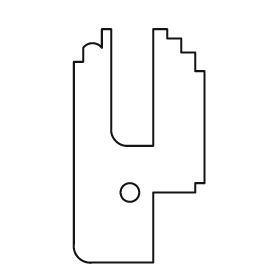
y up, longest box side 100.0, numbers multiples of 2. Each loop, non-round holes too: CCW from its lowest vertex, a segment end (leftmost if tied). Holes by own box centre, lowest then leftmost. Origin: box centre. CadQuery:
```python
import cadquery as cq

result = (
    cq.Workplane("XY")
    .moveTo(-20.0, -50.0)
    .lineTo(6.0, -50.0)
    .lineTo(6.0, -20.0)
    .lineTo(24.0, -20.0)
    .lineTo(24.0, -16.0)
    .lineTo(28.0, -16.0)
    .lineTo(28.0, 32.0)
    .lineTo(24.0, 32.0)
    .lineTo(24.0, 40.0)
    .lineTo(18.0, 40.0)
    .lineTo(18.0, 46.0)
    .lineTo(12.0, 46.0)
    .lineTo(12.0, 50.0)
    .lineTo(6.0, 50.0)
    .lineTo(6.0, 0.0)
    .lineTo(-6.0, 0.0)
    .threePointArc((-10.0, 2.0), (-12.0, 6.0))
    .lineTo(-12.0, 50.0)
    .lineTo(-16.0, 50.0)
    .lineTo(-16.0, 42.0)
    .threePointArc((-20.0, 44.0), (-24.0, 42.0))
    .lineTo(-24.0, 36.0)
    .lineTo(-28.0, 36.0)
    .lineTo(-28.0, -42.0)
    .threePointArc((-26.0, -48.0), (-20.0, -50.0))
    .close()
    .moveTo(-4.0, -20.0)
    .circle(4.0)
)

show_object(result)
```